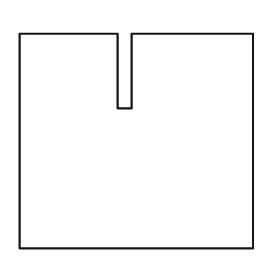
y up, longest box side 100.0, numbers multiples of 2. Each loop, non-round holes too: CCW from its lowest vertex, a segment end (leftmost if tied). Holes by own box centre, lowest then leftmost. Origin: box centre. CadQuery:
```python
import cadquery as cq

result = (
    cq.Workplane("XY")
    .moveTo(-50.0, -46.0)
    .lineTo(50.0, -46.0)
    .lineTo(50.0, 46.0)
    .lineTo(-2.0, 46.0)
    .lineTo(-2.0, 14.0)
    .lineTo(-8.0, 14.0)
    .lineTo(-8.0, 46.0)
    .lineTo(-50.0, 46.0)
    .close()
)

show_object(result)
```